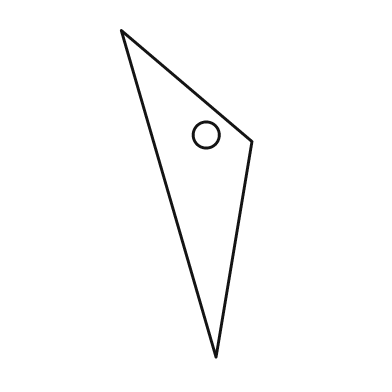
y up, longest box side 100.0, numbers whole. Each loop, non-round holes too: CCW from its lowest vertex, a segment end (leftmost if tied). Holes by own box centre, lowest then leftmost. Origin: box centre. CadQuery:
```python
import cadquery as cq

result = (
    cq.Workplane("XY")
    .moveTo(9.0, -50.0)
    .lineTo(20.0, 16.0)
    .lineTo(-20.0, 50.0)
    .close()
    .moveTo(6.0, 18.0)
    .circle(4.0)
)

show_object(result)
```